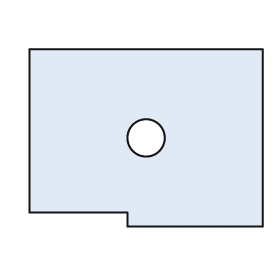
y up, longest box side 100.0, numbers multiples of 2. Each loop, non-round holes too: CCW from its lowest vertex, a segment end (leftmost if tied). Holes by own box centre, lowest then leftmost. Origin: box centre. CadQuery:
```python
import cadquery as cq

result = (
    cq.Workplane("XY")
    .moveTo(-8.0, -38.0)
    .lineTo(50.0, -38.0)
    .lineTo(50.0, 38.0)
    .lineTo(-50.0, 38.0)
    .lineTo(-50.0, -32.0)
    .lineTo(-8.0, -32.0)
    .close()
    .moveTo(0.0, 0.0)
    .circle(8.0)
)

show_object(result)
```